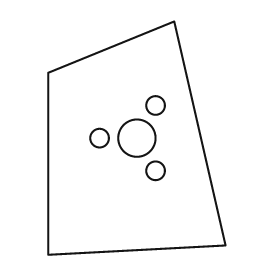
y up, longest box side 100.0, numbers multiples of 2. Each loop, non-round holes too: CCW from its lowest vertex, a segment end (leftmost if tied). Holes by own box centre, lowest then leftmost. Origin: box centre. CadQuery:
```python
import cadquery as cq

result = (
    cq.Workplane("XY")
    .moveTo(-38.0, -50.0)
    .lineTo(38.0, -46.0)
    .lineTo(16.0, 50.0)
    .lineTo(-38.0, 28.0)
    .close()
    .moveTo(8.0, -14.0)
    .circle(4.0)
    .moveTo(-16.0, 0.0)
    .circle(4.0)
    .moveTo(0.0, 0.0)
    .circle(8.0)
    .moveTo(8.0, 14.0)
    .circle(4.0)
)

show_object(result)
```